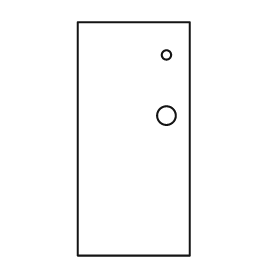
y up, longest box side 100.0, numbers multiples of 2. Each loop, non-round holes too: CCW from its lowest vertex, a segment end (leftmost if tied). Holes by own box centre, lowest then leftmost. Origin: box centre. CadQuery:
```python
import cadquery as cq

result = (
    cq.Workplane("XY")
    .moveTo(-24.0, -50.0)
    .lineTo(24.0, -50.0)
    .lineTo(24.0, 50.0)
    .lineTo(-24.0, 50.0)
    .close()
    .moveTo(14.0, 10.0)
    .circle(4.0)
    .moveTo(14.0, 36.0)
    .circle(2.0)
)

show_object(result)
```